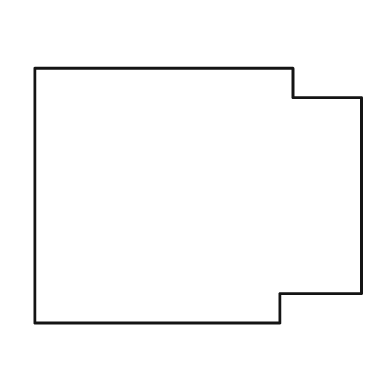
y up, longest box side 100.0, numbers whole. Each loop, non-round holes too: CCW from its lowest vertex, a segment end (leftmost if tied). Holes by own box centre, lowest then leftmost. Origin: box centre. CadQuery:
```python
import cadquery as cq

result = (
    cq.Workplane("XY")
    .moveTo(-50.0, -39.0)
    .lineTo(25.0, -39.0)
    .lineTo(25.0, -30.0)
    .lineTo(50.0, -30.0)
    .lineTo(50.0, 30.0)
    .lineTo(29.0, 30.0)
    .lineTo(29.0, 39.0)
    .lineTo(-50.0, 39.0)
    .close()
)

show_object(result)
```